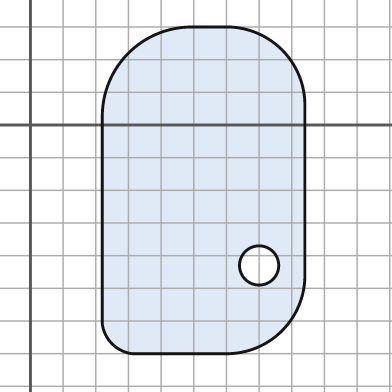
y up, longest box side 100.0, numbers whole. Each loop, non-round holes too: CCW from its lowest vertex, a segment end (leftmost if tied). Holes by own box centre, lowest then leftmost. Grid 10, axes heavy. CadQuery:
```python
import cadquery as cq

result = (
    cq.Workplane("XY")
    .moveTo(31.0, -70.0)
    .lineTo(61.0, -70.0)
    .threePointArc((77.0, -63.0), (84.0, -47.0))
    .lineTo(84.0, 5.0)
    .threePointArc((77.0, 23.0), (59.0, 30.0))
    .lineTo(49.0, 30.0)
    .threePointArc((30.0, 22.0), (22.0, 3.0))
    .lineTo(22.0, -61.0)
    .threePointArc((25.0, -67.0), (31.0, -70.0))
    .close()
    .moveTo(70.0, -43.0)
    .circle(6.0)
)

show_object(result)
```